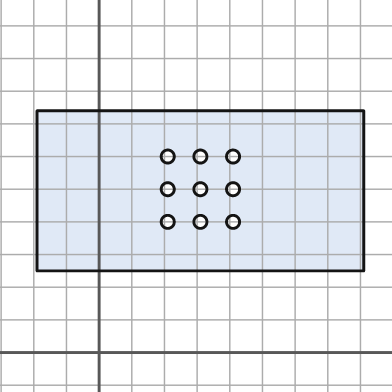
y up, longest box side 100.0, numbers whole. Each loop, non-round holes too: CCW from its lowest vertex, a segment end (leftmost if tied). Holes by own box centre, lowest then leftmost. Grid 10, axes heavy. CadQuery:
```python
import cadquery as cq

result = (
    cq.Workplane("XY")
    .moveTo(-19.0, 25.0)
    .lineTo(81.0, 25.0)
    .lineTo(81.0, 74.0)
    .lineTo(-19.0, 74.0)
    .close()
    .moveTo(21.0, 40.0)
    .circle(2.0)
    .moveTo(31.0, 40.0)
    .circle(2.0)
    .moveTo(41.0, 40.0)
    .circle(2.0)
    .moveTo(21.0, 50.0)
    .circle(2.0)
    .moveTo(31.0, 50.0)
    .circle(2.0)
    .moveTo(41.0, 50.0)
    .circle(2.0)
    .moveTo(21.0, 60.0)
    .circle(2.0)
    .moveTo(31.0, 60.0)
    .circle(2.0)
    .moveTo(41.0, 60.0)
    .circle(2.0)
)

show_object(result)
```